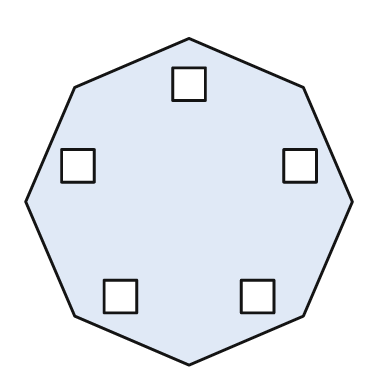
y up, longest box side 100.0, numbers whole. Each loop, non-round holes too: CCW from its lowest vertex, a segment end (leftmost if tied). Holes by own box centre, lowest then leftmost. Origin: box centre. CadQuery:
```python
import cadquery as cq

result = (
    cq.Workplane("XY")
    .moveTo(0.0, -50.0)
    .lineTo(35.0, -35.0)
    .lineTo(50.0, 0.0)
    .lineTo(35.0, 35.0)
    .lineTo(0.0, 50.0)
    .lineTo(-35.0, 35.0)
    .lineTo(-50.0, 0.0)
    .lineTo(-35.0, -35.0)
    .close()
    .moveTo(-26.0, -34.0)
    .lineTo(-16.0, -34.0)
    .lineTo(-16.0, -24.0)
    .lineTo(-26.0, -24.0)
    .close()
    .moveTo(16.0, -34.0)
    .lineTo(26.0, -34.0)
    .lineTo(26.0, -24.0)
    .lineTo(16.0, -24.0)
    .close()
    .moveTo(-39.0, 6.0)
    .lineTo(-29.0, 6.0)
    .lineTo(-29.0, 16.0)
    .lineTo(-39.0, 16.0)
    .close()
    .moveTo(29.0, 6.0)
    .lineTo(39.0, 6.0)
    .lineTo(39.0, 16.0)
    .lineTo(29.0, 16.0)
    .close()
    .moveTo(-5.0, 31.0)
    .lineTo(5.0, 31.0)
    .lineTo(5.0, 41.0)
    .lineTo(-5.0, 41.0)
    .close()
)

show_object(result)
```